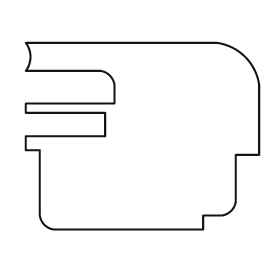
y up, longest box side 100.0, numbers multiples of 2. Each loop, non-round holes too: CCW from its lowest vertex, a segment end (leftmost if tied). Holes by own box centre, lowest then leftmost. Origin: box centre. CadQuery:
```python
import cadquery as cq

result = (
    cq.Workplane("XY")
    .moveTo(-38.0, -40.0)
    .lineTo(26.0, -40.0)
    .lineTo(26.0, -34.0)
    .lineTo(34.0, -34.0)
    .threePointArc((38.0, -32.0), (40.0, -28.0))
    .lineTo(40.0, -8.0)
    .lineTo(50.0, -8.0)
    .lineTo(50.0, 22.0)
    .threePointArc((44.0, 34.0), (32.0, 40.0))
    .lineTo(-50.0, 40.0)
    .threePointArc((-48.0, 34.0), (-50.0, 28.0))
    .lineTo(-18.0, 28.0)
    .threePointArc((-14.0, 26.0), (-12.0, 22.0))
    .lineTo(-12.0, 14.0)
    .lineTo(-50.0, 14.0)
    .lineTo(-50.0, 10.0)
    .lineTo(-16.0, 10.0)
    .lineTo(-16.0, 0.0)
    .lineTo(-50.0, 0.0)
    .lineTo(-50.0, -6.0)
    .lineTo(-44.0, -6.0)
    .lineTo(-44.0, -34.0)
    .threePointArc((-42.0, -38.0), (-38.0, -40.0))
    .close()
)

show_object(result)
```